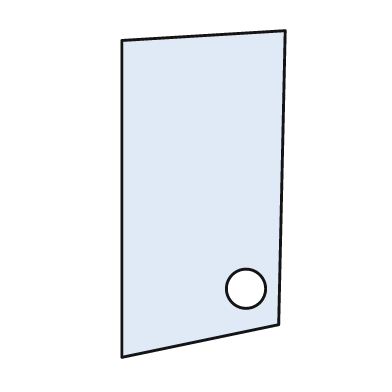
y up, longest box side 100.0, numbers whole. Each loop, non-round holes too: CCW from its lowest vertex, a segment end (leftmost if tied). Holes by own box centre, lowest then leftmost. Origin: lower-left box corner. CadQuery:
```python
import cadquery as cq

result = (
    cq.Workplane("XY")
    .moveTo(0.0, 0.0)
    .lineTo(48.0, 10.0)
    .lineTo(50.0, 100.0)
    .lineTo(0.0, 97.0)
    .close()
    .moveTo(38.0, 21.0)
    .circle(6.0)
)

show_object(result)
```